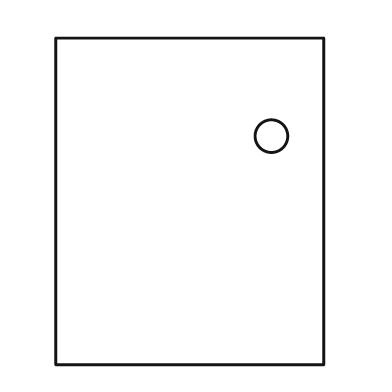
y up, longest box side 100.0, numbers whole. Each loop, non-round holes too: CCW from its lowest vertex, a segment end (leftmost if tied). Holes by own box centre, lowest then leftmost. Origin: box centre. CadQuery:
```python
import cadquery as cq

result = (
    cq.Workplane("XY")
    .moveTo(-41.0, -50.0)
    .lineTo(41.0, -50.0)
    .lineTo(41.0, 50.0)
    .lineTo(-41.0, 50.0)
    .close()
    .moveTo(25.0, 20.0)
    .circle(5.0)
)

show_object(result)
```